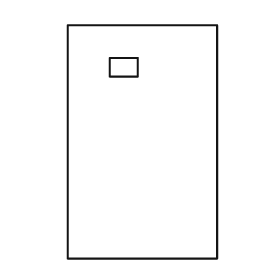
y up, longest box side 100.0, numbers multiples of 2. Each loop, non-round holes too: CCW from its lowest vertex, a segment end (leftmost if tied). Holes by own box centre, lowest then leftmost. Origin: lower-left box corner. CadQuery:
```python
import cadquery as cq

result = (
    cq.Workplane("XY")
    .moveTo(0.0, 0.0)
    .lineTo(64.0, 0.0)
    .lineTo(64.0, 100.0)
    .lineTo(0.0, 100.0)
    .close()
    .moveTo(18.0, 78.0)
    .lineTo(30.0, 78.0)
    .lineTo(30.0, 86.0)
    .lineTo(18.0, 86.0)
    .close()
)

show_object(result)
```